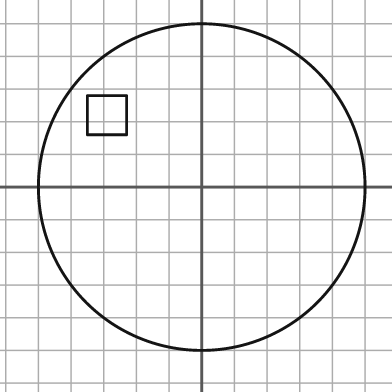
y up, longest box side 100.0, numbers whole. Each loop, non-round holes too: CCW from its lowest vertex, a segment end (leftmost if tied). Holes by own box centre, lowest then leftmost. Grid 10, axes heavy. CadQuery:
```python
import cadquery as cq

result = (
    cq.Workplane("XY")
    .moveTo(0.0, 0.0)
    .circle(50.0)
    .moveTo(-35.0, 16.0)
    .lineTo(-23.0, 16.0)
    .lineTo(-23.0, 28.0)
    .lineTo(-35.0, 28.0)
    .close()
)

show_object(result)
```